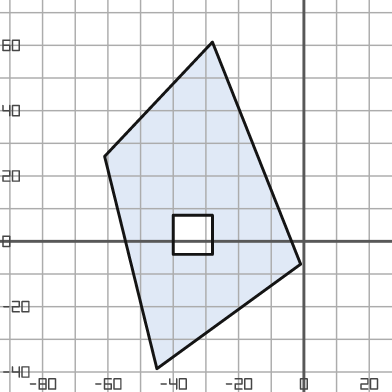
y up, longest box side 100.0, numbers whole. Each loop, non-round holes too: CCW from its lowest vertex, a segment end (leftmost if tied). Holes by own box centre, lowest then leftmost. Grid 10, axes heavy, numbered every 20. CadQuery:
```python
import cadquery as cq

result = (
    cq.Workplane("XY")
    .moveTo(-45.0, -39.0)
    .lineTo(-1.0, -7.0)
    .lineTo(-28.0, 61.0)
    .lineTo(-61.0, 26.0)
    .close()
    .moveTo(-40.0, -4.0)
    .lineTo(-28.0, -4.0)
    .lineTo(-28.0, 8.0)
    .lineTo(-40.0, 8.0)
    .close()
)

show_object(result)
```